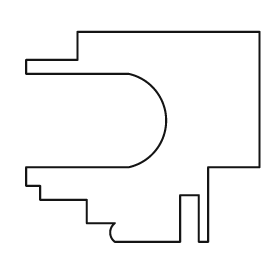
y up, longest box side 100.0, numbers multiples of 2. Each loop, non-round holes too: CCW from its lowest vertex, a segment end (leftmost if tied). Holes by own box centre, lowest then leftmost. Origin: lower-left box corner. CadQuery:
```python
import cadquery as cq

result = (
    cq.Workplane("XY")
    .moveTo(38.0, 0.0)
    .lineTo(66.0, 0.0)
    .lineTo(66.0, 20.0)
    .lineTo(74.0, 20.0)
    .lineTo(74.0, 0.0)
    .lineTo(78.0, 0.0)
    .lineTo(78.0, 32.0)
    .lineTo(100.0, 32.0)
    .lineTo(100.0, 90.0)
    .lineTo(22.0, 90.0)
    .lineTo(22.0, 78.0)
    .lineTo(0.0, 78.0)
    .lineTo(0.0, 72.0)
    .lineTo(44.0, 72.0)
    .threePointArc((60.0, 52.0), (44.0, 32.0))
    .lineTo(0.0, 32.0)
    .lineTo(0.0, 24.0)
    .lineTo(6.0, 24.0)
    .lineTo(6.0, 18.0)
    .lineTo(26.0, 18.0)
    .lineTo(26.0, 8.0)
    .lineTo(38.0, 8.0)
    .threePointArc((36.0, 4.0), (38.0, 0.0))
    .close()
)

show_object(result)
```